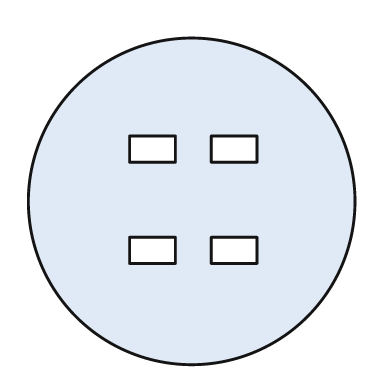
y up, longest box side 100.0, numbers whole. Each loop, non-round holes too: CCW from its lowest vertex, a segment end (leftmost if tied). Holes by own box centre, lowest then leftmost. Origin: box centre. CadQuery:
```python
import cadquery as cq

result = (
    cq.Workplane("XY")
    .moveTo(0.0, 0.0)
    .circle(50.0)
    .moveTo(-19.0, -19.0)
    .lineTo(-5.0, -19.0)
    .lineTo(-5.0, -11.0)
    .lineTo(-19.0, -11.0)
    .close()
    .moveTo(6.0, -19.0)
    .lineTo(20.0, -19.0)
    .lineTo(20.0, -11.0)
    .lineTo(6.0, -11.0)
    .close()
    .moveTo(-19.0, 12.0)
    .lineTo(-5.0, 12.0)
    .lineTo(-5.0, 20.0)
    .lineTo(-19.0, 20.0)
    .close()
    .moveTo(6.0, 12.0)
    .lineTo(20.0, 12.0)
    .lineTo(20.0, 20.0)
    .lineTo(6.0, 20.0)
    .close()
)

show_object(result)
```